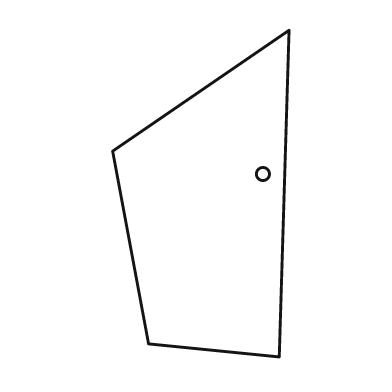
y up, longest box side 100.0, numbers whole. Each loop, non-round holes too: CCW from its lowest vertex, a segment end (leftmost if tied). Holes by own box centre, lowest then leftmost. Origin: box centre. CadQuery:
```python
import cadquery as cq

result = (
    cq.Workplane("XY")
    .moveTo(24.0, -50.0)
    .lineTo(27.0, 50.0)
    .lineTo(-27.0, 13.0)
    .lineTo(-16.0, -46.0)
    .close()
    .moveTo(19.0, 6.0)
    .circle(2.0)
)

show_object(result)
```